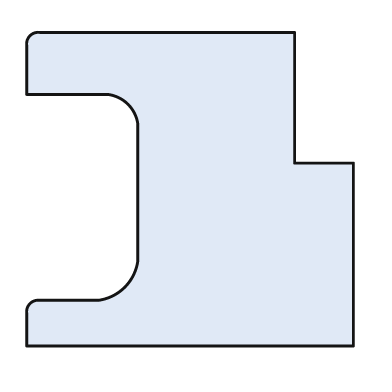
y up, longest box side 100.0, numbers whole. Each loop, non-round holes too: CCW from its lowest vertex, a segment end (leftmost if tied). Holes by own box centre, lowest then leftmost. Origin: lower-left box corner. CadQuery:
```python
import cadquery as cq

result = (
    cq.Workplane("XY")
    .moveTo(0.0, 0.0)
    .lineTo(100.0, 0.0)
    .lineTo(100.0, 56.0)
    .lineTo(82.0, 56.0)
    .lineTo(82.0, 96.0)
    .lineTo(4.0, 96.0)
    .threePointArc((1.0, 95.0), (0.0, 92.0))
    .lineTo(0.0, 77.0)
    .lineTo(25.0, 77.0)
    .threePointArc((31.0, 74.0), (34.0, 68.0))
    .lineTo(34.0, 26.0)
    .threePointArc((30.0, 18.0), (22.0, 14.0))
    .lineTo(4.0, 14.0)
    .threePointArc((1.0, 13.0), (0.0, 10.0))
    .close()
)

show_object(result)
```